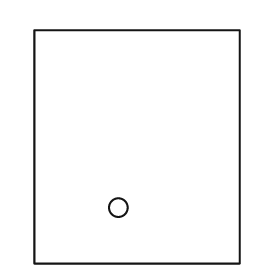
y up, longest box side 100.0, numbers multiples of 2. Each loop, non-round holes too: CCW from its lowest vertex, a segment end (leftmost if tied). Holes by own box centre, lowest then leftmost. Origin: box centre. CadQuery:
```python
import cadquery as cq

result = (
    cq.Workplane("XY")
    .moveTo(-44.0, -50.0)
    .lineTo(44.0, -50.0)
    .lineTo(44.0, 50.0)
    .lineTo(-44.0, 50.0)
    .close()
    .moveTo(-8.0, -26.0)
    .circle(4.0)
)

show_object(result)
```